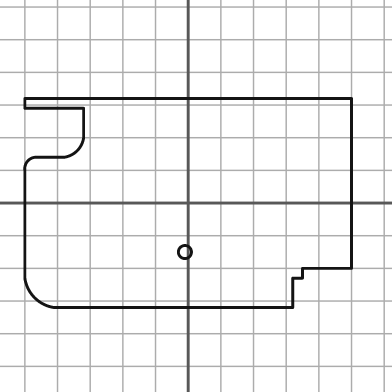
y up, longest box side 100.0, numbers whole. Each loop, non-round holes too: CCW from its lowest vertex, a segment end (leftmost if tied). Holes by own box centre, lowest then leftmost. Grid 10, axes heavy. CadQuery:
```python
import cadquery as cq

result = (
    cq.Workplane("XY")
    .moveTo(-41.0, -32.0)
    .lineTo(32.0, -32.0)
    .lineTo(32.0, -23.0)
    .lineTo(35.0, -23.0)
    .lineTo(35.0, -20.0)
    .lineTo(50.0, -20.0)
    .lineTo(50.0, 32.0)
    .lineTo(-50.0, 32.0)
    .lineTo(-50.0, 29.0)
    .lineTo(-32.0, 29.0)
    .lineTo(-32.0, 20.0)
    .threePointArc((-34.0, 16.0), (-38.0, 14.0))
    .lineTo(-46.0, 14.0)
    .threePointArc((-49.0, 13.0), (-50.0, 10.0))
    .lineTo(-50.0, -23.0)
    .threePointArc((-47.0, -29.0), (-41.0, -32.0))
    .close()
    .moveTo(-1.0, -15.0)
    .circle(2.0)
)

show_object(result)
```